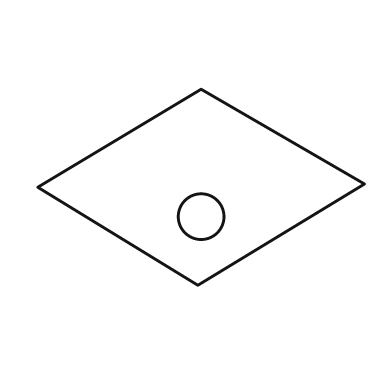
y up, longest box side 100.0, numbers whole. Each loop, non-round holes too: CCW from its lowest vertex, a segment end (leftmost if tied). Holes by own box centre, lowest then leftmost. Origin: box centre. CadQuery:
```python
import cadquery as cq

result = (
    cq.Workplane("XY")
    .moveTo(-1.0, -30.0)
    .lineTo(50.0, 1.0)
    .lineTo(0.0, 30.0)
    .lineTo(-50.0, 0.0)
    .close()
    .moveTo(0.0, -9.0)
    .circle(7.0)
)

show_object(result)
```